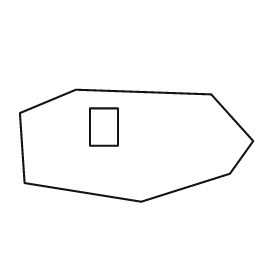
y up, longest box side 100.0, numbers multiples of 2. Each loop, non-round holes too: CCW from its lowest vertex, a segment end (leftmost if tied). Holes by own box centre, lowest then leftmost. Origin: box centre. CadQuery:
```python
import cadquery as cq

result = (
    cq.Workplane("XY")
    .moveTo(2.0, -24.0)
    .lineTo(40.0, -12.0)
    .lineTo(50.0, 2.0)
    .lineTo(32.0, 22.0)
    .lineTo(-26.0, 24.0)
    .lineTo(-50.0, 14.0)
    .lineTo(-48.0, -16.0)
    .close()
    .moveTo(-20.0, 0.0)
    .lineTo(-8.0, 0.0)
    .lineTo(-8.0, 16.0)
    .lineTo(-20.0, 16.0)
    .close()
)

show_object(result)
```